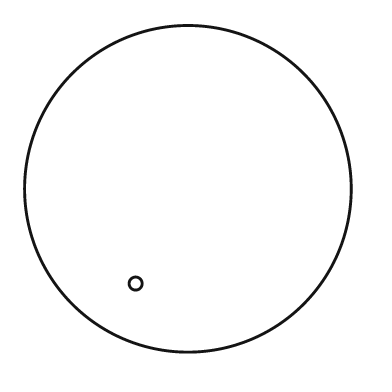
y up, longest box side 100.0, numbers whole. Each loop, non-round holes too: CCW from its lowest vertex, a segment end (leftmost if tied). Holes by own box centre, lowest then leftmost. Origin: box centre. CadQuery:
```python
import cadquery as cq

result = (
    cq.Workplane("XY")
    .moveTo(0.0, 0.0)
    .circle(50.0)
    .moveTo(-16.0, -29.0)
    .circle(2.0)
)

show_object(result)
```